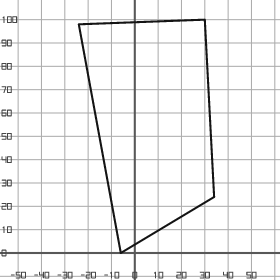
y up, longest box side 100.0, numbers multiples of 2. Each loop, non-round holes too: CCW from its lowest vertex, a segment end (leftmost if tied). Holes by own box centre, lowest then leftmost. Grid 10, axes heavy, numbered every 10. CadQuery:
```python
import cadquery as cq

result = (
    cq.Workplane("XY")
    .moveTo(-6.0, 0.0)
    .lineTo(34.0, 24.0)
    .lineTo(30.0, 100.0)
    .lineTo(-24.0, 98.0)
    .close()
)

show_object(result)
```